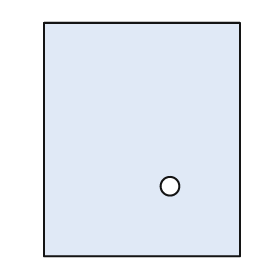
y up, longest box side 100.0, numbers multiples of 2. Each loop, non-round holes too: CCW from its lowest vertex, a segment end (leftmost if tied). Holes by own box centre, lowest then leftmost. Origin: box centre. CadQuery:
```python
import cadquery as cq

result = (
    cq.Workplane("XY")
    .moveTo(-42.0, -50.0)
    .lineTo(42.0, -50.0)
    .lineTo(42.0, 50.0)
    .lineTo(-42.0, 50.0)
    .close()
    .moveTo(12.0, -20.0)
    .circle(4.0)
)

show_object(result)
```